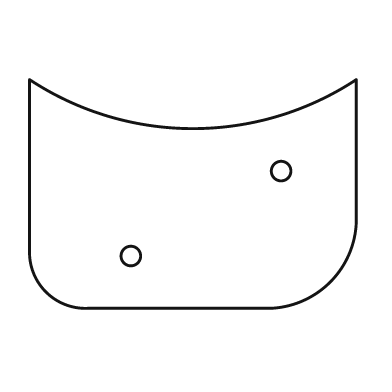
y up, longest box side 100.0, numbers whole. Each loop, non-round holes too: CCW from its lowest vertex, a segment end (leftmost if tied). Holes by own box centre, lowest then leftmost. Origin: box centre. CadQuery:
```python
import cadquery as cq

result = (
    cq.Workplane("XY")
    .moveTo(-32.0, -35.0)
    .lineTo(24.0, -35.0)
    .threePointArc((42.0, -27.0), (50.0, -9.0))
    .lineTo(50.0, 35.0)
    .threePointArc((0.0, 20.0), (-50.0, 35.0))
    .lineTo(-50.0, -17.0)
    .threePointArc((-45.0, -30.0), (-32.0, -35.0))
    .close()
    .moveTo(-19.0, -19.0)
    .circle(3.0)
    .moveTo(27.0, 7.0)
    .circle(3.0)
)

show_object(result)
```